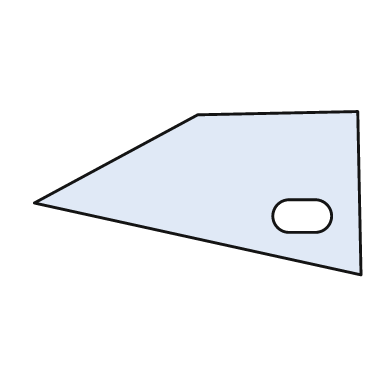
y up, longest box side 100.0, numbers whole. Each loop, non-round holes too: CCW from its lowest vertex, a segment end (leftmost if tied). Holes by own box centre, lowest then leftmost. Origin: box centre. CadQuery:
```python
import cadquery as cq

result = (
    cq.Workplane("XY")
    .moveTo(50.0, -25.0)
    .lineTo(49.0, 25.0)
    .lineTo(0.0, 24.0)
    .lineTo(-50.0, -3.0)
    .close()
    .moveTo(28.0, -12.0)
    .lineTo(36.0, -12.0)
    .threePointArc((41.0, -7.0), (36.0, -2.0))
    .lineTo(28.0, -2.0)
    .threePointArc((23.0, -7.0), (28.0, -12.0))
    .close()
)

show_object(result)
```